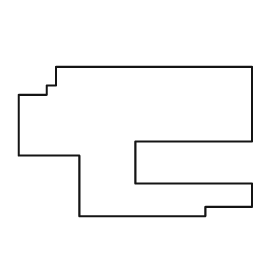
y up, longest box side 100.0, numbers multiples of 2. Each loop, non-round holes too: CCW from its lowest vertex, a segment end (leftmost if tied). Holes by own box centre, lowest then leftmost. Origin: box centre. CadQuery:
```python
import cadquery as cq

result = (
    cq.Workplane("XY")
    .moveTo(-24.0, -32.0)
    .lineTo(30.0, -32.0)
    .lineTo(30.0, -28.0)
    .lineTo(50.0, -28.0)
    .lineTo(50.0, -18.0)
    .lineTo(0.0, -18.0)
    .lineTo(0.0, 0.0)
    .lineTo(50.0, 0.0)
    .lineTo(50.0, 32.0)
    .lineTo(-34.0, 32.0)
    .lineTo(-34.0, 24.0)
    .lineTo(-38.0, 24.0)
    .lineTo(-38.0, 20.0)
    .lineTo(-50.0, 20.0)
    .lineTo(-50.0, -6.0)
    .lineTo(-24.0, -6.0)
    .close()
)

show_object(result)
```